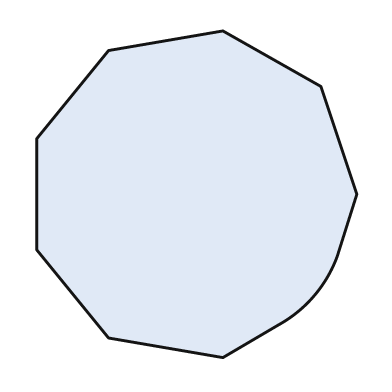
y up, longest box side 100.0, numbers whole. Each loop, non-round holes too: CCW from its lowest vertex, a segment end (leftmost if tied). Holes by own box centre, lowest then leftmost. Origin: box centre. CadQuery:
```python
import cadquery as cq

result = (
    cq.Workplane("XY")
    .moveTo(8.0, -50.0)
    .lineTo(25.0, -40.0)
    .threePointArc((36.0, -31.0), (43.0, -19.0))
    .lineTo(49.0, 0.0)
    .lineTo(38.0, 33.0)
    .lineTo(8.0, 50.0)
    .lineTo(-27.0, 44.0)
    .lineTo(-49.0, 17.0)
    .lineTo(-49.0, -17.0)
    .lineTo(-27.0, -44.0)
    .close()
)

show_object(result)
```